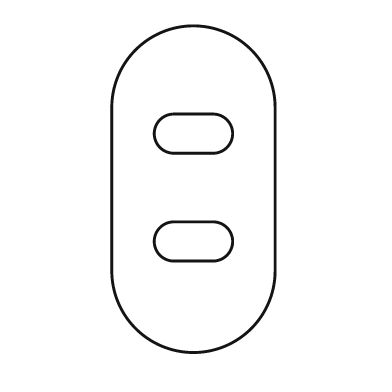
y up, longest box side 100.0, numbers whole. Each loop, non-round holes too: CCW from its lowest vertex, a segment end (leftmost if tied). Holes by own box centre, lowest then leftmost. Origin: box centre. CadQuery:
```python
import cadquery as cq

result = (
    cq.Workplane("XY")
    .moveTo(-25.0, -25.0)
    .threePointArc((0.0, -50.0), (25.0, -25.0))
    .lineTo(25.0, 25.0)
    .threePointArc((0.0, 50.0), (-25.0, 25.0))
    .close()
    .moveTo(-6.0, -22.0)
    .lineTo(6.0, -22.0)
    .threePointArc((12.0, -16.0), (6.0, -10.0))
    .lineTo(-6.0, -10.0)
    .threePointArc((-12.0, -16.0), (-6.0, -22.0))
    .close()
    .moveTo(-6.0, 11.0)
    .lineTo(6.0, 11.0)
    .threePointArc((12.0, 17.0), (6.0, 23.0))
    .lineTo(-6.0, 23.0)
    .threePointArc((-12.0, 17.0), (-6.0, 11.0))
    .close()
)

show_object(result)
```